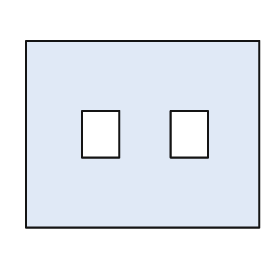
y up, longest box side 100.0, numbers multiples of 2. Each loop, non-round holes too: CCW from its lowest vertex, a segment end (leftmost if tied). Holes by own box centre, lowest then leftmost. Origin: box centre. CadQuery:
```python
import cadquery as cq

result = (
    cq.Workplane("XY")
    .moveTo(-50.0, -40.0)
    .lineTo(50.0, -40.0)
    .lineTo(50.0, 40.0)
    .lineTo(-50.0, 40.0)
    .close()
    .moveTo(-26.0, -10.0)
    .lineTo(-10.0, -10.0)
    .lineTo(-10.0, 10.0)
    .lineTo(-26.0, 10.0)
    .close()
    .moveTo(12.0, -10.0)
    .lineTo(28.0, -10.0)
    .lineTo(28.0, 10.0)
    .lineTo(12.0, 10.0)
    .close()
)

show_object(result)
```